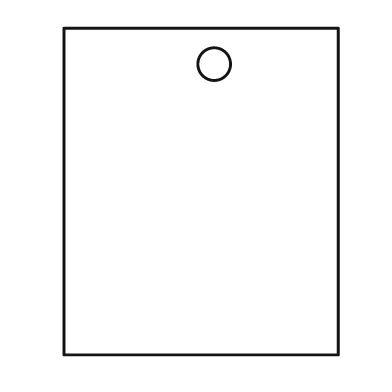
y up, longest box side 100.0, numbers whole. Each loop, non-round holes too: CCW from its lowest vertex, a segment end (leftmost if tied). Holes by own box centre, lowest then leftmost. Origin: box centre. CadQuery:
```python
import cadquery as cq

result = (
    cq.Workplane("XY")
    .moveTo(-42.0, -50.0)
    .lineTo(42.0, -50.0)
    .lineTo(42.0, 50.0)
    .lineTo(-42.0, 50.0)
    .close()
    .moveTo(4.0, 39.0)
    .circle(5.0)
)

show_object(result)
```